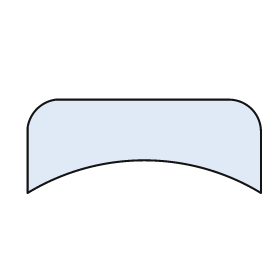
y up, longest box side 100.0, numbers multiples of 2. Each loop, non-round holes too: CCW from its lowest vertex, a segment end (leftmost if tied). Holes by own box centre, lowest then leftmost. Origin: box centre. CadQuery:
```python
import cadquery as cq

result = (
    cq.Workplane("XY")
    .moveTo(-50.0, -20.0)
    .threePointArc((0.0, -6.0), (50.0, -20.0))
    .lineTo(50.0, 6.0)
    .threePointArc((46.0, 16.0), (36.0, 20.0))
    .lineTo(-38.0, 20.0)
    .threePointArc((-46.0, 16.0), (-50.0, 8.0))
    .close()
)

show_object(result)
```